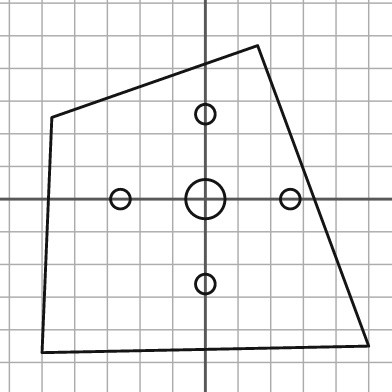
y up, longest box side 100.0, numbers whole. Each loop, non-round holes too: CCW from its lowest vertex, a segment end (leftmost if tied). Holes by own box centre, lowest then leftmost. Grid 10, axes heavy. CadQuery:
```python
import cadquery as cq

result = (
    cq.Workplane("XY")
    .moveTo(-50.0, -47.0)
    .lineTo(50.0, -45.0)
    .lineTo(16.0, 47.0)
    .lineTo(-47.0, 25.0)
    .close()
    .moveTo(0.0, -26.0)
    .circle(3.0)
    .moveTo(-26.0, 0.0)
    .circle(3.0)
    .moveTo(0.0, 0.0)
    .circle(6.0)
    .moveTo(26.0, 0.0)
    .circle(3.0)
    .moveTo(0.0, 26.0)
    .circle(3.0)
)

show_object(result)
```